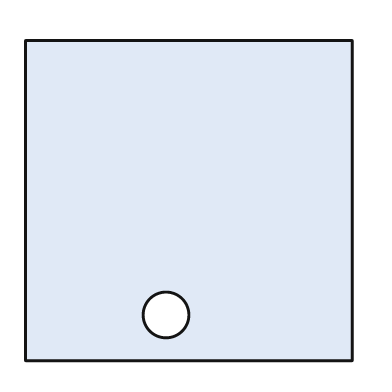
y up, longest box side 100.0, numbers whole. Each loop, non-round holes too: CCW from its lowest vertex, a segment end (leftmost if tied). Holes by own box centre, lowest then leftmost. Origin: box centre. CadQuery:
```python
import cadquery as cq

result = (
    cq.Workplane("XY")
    .moveTo(-50.0, -49.0)
    .lineTo(50.0, -49.0)
    .lineTo(50.0, 49.0)
    .lineTo(-50.0, 49.0)
    .close()
    .moveTo(-7.0, -35.0)
    .circle(7.0)
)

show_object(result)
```